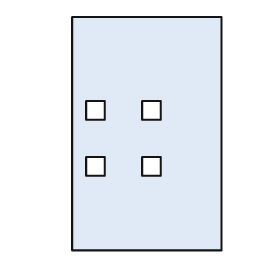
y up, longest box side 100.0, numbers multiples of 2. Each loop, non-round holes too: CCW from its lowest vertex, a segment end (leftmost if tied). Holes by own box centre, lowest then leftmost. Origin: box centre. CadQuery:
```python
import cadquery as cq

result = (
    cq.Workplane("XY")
    .moveTo(-32.0, -50.0)
    .lineTo(32.0, -50.0)
    .lineTo(32.0, 50.0)
    .lineTo(-32.0, 50.0)
    .close()
    .moveTo(-26.0, -18.0)
    .lineTo(-18.0, -18.0)
    .lineTo(-18.0, -10.0)
    .lineTo(-26.0, -10.0)
    .close()
    .moveTo(-2.0, -18.0)
    .lineTo(6.0, -18.0)
    .lineTo(6.0, -10.0)
    .lineTo(-2.0, -10.0)
    .close()
    .moveTo(-26.0, 6.0)
    .lineTo(-18.0, 6.0)
    .lineTo(-18.0, 14.0)
    .lineTo(-26.0, 14.0)
    .close()
    .moveTo(-2.0, 6.0)
    .lineTo(6.0, 6.0)
    .lineTo(6.0, 14.0)
    .lineTo(-2.0, 14.0)
    .close()
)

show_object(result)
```